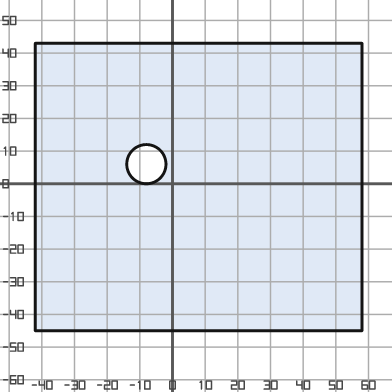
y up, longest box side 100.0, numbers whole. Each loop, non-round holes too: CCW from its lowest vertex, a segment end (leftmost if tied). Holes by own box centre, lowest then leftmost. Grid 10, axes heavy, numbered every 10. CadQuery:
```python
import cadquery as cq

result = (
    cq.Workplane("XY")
    .moveTo(-42.0, -45.0)
    .lineTo(58.0, -45.0)
    .lineTo(58.0, 43.0)
    .lineTo(-42.0, 43.0)
    .close()
    .moveTo(-8.0, 6.0)
    .circle(6.0)
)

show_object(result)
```